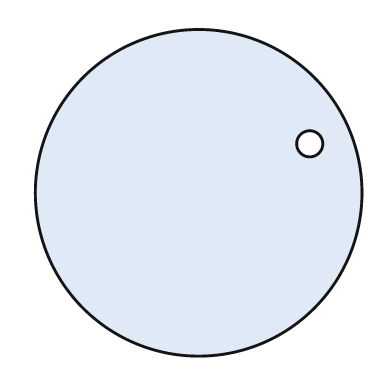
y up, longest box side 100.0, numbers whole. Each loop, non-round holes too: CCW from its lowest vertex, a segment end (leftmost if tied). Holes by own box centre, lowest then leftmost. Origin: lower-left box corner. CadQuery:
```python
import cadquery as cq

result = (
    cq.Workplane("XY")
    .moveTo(50.0, 50.0)
    .circle(50.0)
    .moveTo(84.0, 65.0)
    .circle(4.0)
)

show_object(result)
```